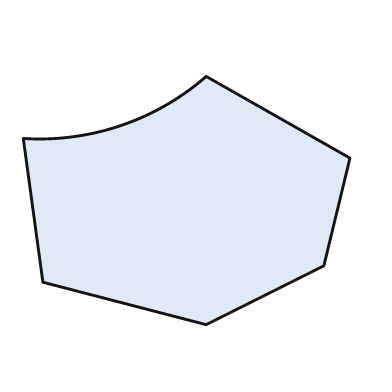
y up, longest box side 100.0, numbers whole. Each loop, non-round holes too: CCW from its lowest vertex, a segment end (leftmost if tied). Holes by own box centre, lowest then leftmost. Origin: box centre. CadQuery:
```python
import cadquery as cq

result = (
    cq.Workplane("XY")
    .moveTo(6.0, -38.0)
    .lineTo(42.0, -20.0)
    .lineTo(50.0, 13.0)
    .lineTo(6.0, 38.0)
    .threePointArc((-20.0, 23.0), (-50.0, 19.0))
    .lineTo(-44.0, -25.0)
    .close()
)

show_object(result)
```